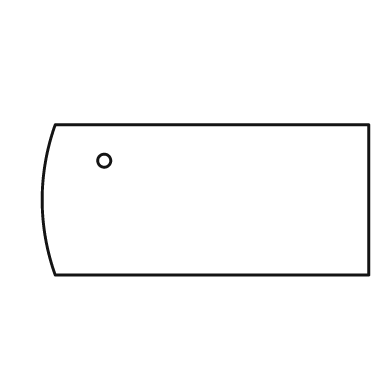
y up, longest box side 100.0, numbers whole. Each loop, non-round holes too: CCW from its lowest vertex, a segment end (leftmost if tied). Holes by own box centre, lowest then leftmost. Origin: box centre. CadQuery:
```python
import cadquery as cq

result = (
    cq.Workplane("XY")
    .moveTo(-46.0, -23.0)
    .lineTo(50.0, -23.0)
    .lineTo(50.0, 23.0)
    .lineTo(-46.0, 23.0)
    .threePointArc((-50.0, 0.0), (-46.0, -23.0))
    .close()
    .moveTo(-31.0, 12.0)
    .circle(2.0)
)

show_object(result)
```